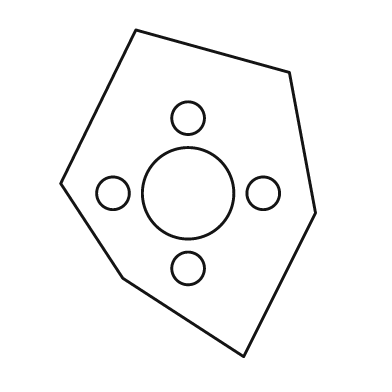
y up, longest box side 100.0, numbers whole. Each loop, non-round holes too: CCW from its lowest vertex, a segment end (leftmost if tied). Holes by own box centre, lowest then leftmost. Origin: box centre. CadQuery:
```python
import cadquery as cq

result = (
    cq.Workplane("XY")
    .moveTo(17.0, -50.0)
    .lineTo(39.0, -6.0)
    .lineTo(31.0, 37.0)
    .lineTo(-16.0, 50.0)
    .lineTo(-39.0, 3.0)
    .lineTo(-20.0, -26.0)
    .close()
    .moveTo(0.0, -23.0)
    .circle(5.0)
    .moveTo(-23.0, 0.0)
    .circle(5.0)
    .moveTo(0.0, 0.0)
    .circle(14.0)
    .moveTo(23.0, 0.0)
    .circle(5.0)
    .moveTo(0.0, 23.0)
    .circle(5.0)
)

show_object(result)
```